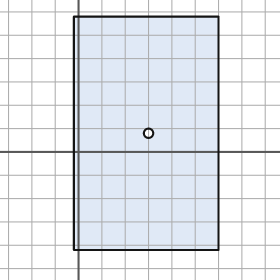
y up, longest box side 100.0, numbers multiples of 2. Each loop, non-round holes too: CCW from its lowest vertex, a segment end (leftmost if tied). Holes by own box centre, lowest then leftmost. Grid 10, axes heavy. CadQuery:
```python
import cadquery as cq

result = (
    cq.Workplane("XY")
    .moveTo(-2.0, -42.0)
    .lineTo(60.0, -42.0)
    .lineTo(60.0, 58.0)
    .lineTo(-2.0, 58.0)
    .close()
    .moveTo(30.0, 8.0)
    .circle(2.0)
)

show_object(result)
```